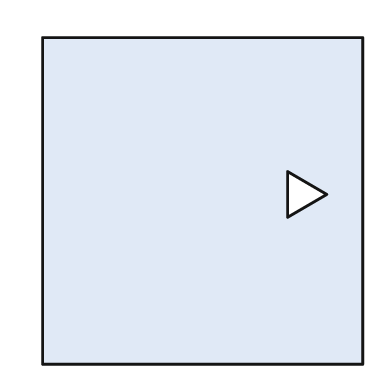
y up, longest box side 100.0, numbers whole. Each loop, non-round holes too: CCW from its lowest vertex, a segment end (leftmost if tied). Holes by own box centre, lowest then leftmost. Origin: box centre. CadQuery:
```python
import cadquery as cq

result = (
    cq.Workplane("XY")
    .moveTo(-49.0, -50.0)
    .lineTo(49.0, -50.0)
    .lineTo(49.0, 50.0)
    .lineTo(-49.0, 50.0)
    .close()
    .moveTo(26.0, -5.0)
    .lineTo(38.0, 2.0)
    .lineTo(26.0, 9.0)
    .close()
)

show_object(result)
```